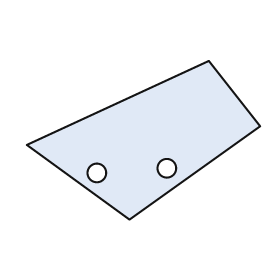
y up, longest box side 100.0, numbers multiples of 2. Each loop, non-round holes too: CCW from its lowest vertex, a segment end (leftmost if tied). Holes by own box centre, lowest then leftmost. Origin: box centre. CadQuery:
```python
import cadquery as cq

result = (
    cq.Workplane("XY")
    .moveTo(-6.0, -34.0)
    .lineTo(50.0, 6.0)
    .lineTo(28.0, 34.0)
    .lineTo(-50.0, -2.0)
    .close()
    .moveTo(-20.0, -14.0)
    .circle(4.0)
    .moveTo(10.0, -12.0)
    .circle(4.0)
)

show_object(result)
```